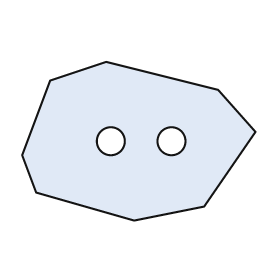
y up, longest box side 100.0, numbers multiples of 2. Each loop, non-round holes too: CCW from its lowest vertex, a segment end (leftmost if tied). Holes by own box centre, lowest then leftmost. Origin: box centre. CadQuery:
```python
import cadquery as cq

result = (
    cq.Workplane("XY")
    .moveTo(-2.0, -34.0)
    .lineTo(28.0, -28.0)
    .lineTo(50.0, 4.0)
    .lineTo(34.0, 22.0)
    .lineTo(-14.0, 34.0)
    .lineTo(-38.0, 26.0)
    .lineTo(-50.0, -6.0)
    .lineTo(-44.0, -22.0)
    .close()
    .moveTo(-12.0, 0.0)
    .circle(6.0)
    .moveTo(14.0, 0.0)
    .circle(6.0)
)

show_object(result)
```